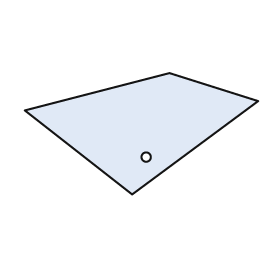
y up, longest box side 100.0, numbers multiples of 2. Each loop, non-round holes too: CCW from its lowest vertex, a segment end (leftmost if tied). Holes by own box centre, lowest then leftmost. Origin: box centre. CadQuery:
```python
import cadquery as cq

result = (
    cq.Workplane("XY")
    .moveTo(-4.0, -26.0)
    .lineTo(50.0, 14.0)
    .lineTo(12.0, 26.0)
    .lineTo(-50.0, 10.0)
    .close()
    .moveTo(2.0, -10.0)
    .circle(2.0)
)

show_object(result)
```